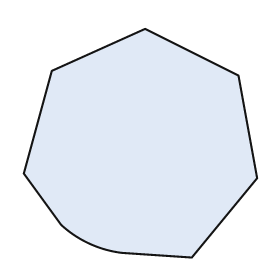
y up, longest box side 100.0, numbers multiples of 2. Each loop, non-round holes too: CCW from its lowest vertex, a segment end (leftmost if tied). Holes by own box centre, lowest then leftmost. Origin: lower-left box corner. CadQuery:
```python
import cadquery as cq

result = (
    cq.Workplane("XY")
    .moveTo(72.0, 0.0)
    .lineTo(100.0, 34.0)
    .lineTo(92.0, 78.0)
    .lineTo(52.0, 98.0)
    .lineTo(12.0, 80.0)
    .lineTo(0.0, 36.0)
    .lineTo(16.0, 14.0)
    .threePointArc((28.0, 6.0), (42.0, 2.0))
    .close()
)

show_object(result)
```